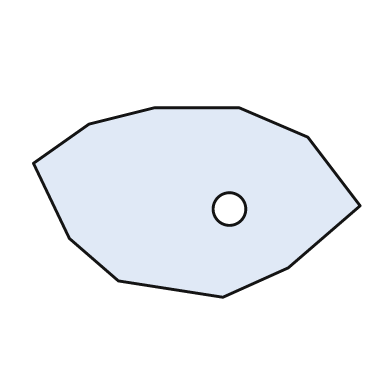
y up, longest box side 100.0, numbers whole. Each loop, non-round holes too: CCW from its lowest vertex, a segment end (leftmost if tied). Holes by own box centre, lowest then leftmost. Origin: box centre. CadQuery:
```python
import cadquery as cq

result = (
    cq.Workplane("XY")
    .moveTo(8.0, -29.0)
    .lineTo(28.0, -20.0)
    .lineTo(50.0, -1.0)
    .lineTo(34.0, 20.0)
    .lineTo(13.0, 29.0)
    .lineTo(-13.0, 29.0)
    .lineTo(-33.0, 24.0)
    .lineTo(-50.0, 12.0)
    .lineTo(-39.0, -11.0)
    .lineTo(-24.0, -24.0)
    .close()
    .moveTo(10.0, -2.0)
    .circle(5.0)
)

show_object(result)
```